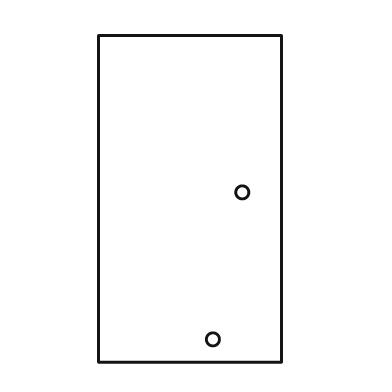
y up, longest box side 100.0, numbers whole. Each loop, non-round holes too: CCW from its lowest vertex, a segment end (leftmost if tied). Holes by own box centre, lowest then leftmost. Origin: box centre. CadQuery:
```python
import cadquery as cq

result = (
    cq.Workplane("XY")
    .moveTo(-28.0, -50.0)
    .lineTo(28.0, -50.0)
    .lineTo(28.0, 50.0)
    .lineTo(-28.0, 50.0)
    .close()
    .moveTo(7.0, -43.0)
    .circle(2.0)
    .moveTo(16.0, 2.0)
    .circle(2.0)
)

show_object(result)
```